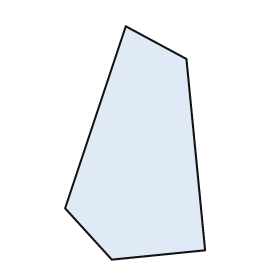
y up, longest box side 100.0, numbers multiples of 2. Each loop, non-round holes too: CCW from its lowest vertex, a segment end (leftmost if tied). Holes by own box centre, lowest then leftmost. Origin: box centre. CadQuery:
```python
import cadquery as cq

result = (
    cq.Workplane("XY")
    .moveTo(-10.0, -50.0)
    .lineTo(30.0, -46.0)
    .lineTo(22.0, 36.0)
    .lineTo(-4.0, 50.0)
    .lineTo(-30.0, -28.0)
    .close()
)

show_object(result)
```